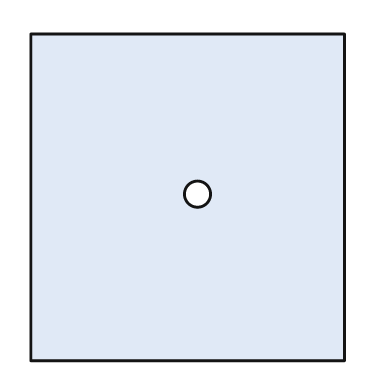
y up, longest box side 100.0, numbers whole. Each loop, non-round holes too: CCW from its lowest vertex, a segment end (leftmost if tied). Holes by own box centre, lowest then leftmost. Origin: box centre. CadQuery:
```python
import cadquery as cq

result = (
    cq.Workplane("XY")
    .moveTo(-48.0, -50.0)
    .lineTo(48.0, -50.0)
    .lineTo(48.0, 50.0)
    .lineTo(-48.0, 50.0)
    .close()
    .moveTo(3.0, 1.0)
    .circle(4.0)
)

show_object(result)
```